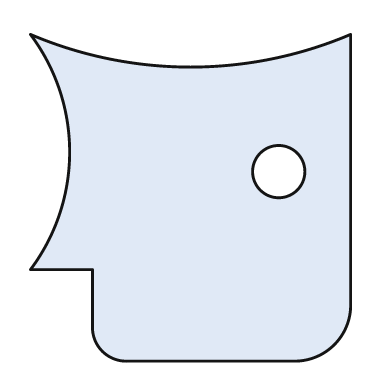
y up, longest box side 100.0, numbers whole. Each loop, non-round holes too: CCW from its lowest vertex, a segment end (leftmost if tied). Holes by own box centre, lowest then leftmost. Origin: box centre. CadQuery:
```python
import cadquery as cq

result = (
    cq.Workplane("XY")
    .moveTo(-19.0, -50.0)
    .lineTo(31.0, -50.0)
    .threePointArc((44.0, -45.0), (49.0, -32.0))
    .lineTo(49.0, 50.0)
    .threePointArc((0.0, 40.0), (-49.0, 50.0))
    .threePointArc((-37.0, 14.0), (-49.0, -22.0))
    .lineTo(-30.0, -22.0)
    .lineTo(-30.0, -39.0)
    .threePointArc((-27.0, -47.0), (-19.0, -50.0))
    .close()
    .moveTo(27.0, 8.0)
    .circle(8.0)
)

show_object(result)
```